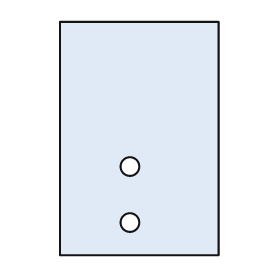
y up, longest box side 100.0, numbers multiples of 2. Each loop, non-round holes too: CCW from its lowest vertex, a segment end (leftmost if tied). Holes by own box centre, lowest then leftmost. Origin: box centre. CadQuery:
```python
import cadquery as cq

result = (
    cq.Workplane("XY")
    .moveTo(-34.0, -50.0)
    .lineTo(34.0, -50.0)
    .lineTo(34.0, 50.0)
    .lineTo(-34.0, 50.0)
    .close()
    .moveTo(-4.0, -36.0)
    .circle(4.0)
    .moveTo(-4.0, -12.0)
    .circle(4.0)
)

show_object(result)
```